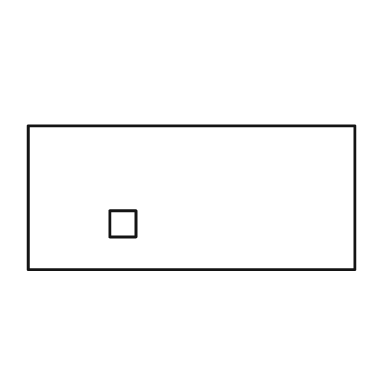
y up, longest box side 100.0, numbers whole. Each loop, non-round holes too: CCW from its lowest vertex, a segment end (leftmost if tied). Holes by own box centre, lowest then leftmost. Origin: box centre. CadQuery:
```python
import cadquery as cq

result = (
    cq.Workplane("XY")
    .moveTo(-50.0, -22.0)
    .lineTo(50.0, -22.0)
    .lineTo(50.0, 22.0)
    .lineTo(-50.0, 22.0)
    .close()
    .moveTo(-25.0, -12.0)
    .lineTo(-17.0, -12.0)
    .lineTo(-17.0, -4.0)
    .lineTo(-25.0, -4.0)
    .close()
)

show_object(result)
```